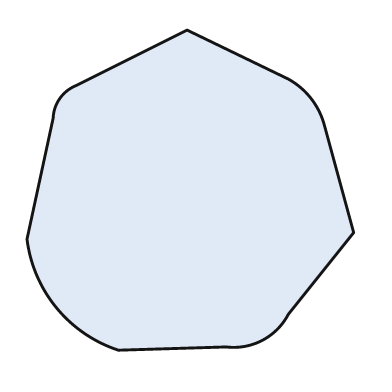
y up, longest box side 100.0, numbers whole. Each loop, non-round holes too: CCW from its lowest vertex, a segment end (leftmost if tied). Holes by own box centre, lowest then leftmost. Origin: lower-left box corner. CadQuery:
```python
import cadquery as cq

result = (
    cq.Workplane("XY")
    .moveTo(28.0, 0.0)
    .lineTo(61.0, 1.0)
    .threePointArc((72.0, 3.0), (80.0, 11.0))
    .lineTo(100.0, 36.0)
    .lineTo(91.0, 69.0)
    .threePointArc((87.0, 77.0), (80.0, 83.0))
    .lineTo(49.0, 98.0)
    .lineTo(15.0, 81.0)
    .threePointArc((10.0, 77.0), (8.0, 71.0))
    .lineTo(0.0, 34.0)
    .threePointArc((9.0, 13.0), (28.0, 0.0))
    .close()
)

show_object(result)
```